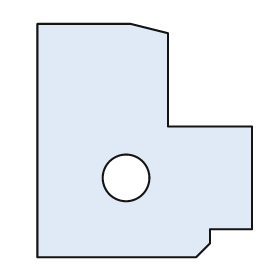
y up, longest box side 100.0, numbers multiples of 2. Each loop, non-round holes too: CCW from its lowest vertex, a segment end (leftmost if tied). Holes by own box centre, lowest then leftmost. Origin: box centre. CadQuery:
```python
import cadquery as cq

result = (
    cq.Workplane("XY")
    .moveTo(-46.0, -50.0)
    .lineTo(22.0, -50.0)
    .lineTo(28.0, -44.0)
    .lineTo(28.0, -38.0)
    .lineTo(46.0, -38.0)
    .lineTo(46.0, 6.0)
    .lineTo(10.0, 6.0)
    .lineTo(10.0, 46.0)
    .lineTo(-6.0, 50.0)
    .lineTo(-46.0, 50.0)
    .close()
    .moveTo(-8.0, -16.0)
    .circle(10.0)
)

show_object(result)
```